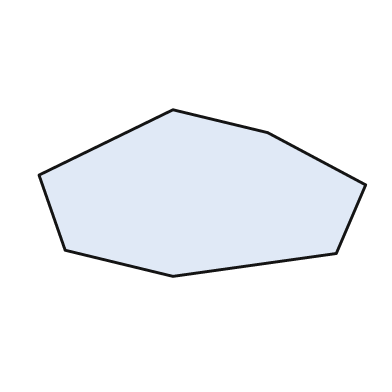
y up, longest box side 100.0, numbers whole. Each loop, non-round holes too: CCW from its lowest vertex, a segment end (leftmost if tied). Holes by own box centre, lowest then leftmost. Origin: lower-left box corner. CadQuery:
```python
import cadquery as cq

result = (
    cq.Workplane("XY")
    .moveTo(41.0, 0.0)
    .lineTo(91.0, 7.0)
    .lineTo(100.0, 28.0)
    .lineTo(70.0, 44.0)
    .lineTo(41.0, 51.0)
    .lineTo(0.0, 31.0)
    .lineTo(8.0, 8.0)
    .close()
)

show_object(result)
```